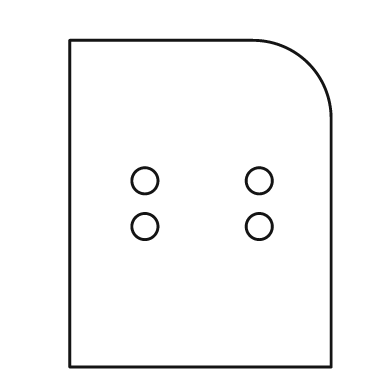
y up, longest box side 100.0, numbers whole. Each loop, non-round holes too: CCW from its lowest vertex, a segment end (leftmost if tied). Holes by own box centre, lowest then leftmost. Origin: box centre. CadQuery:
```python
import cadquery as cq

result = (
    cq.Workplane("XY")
    .moveTo(-40.0, -50.0)
    .lineTo(40.0, -50.0)
    .lineTo(40.0, 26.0)
    .threePointArc((33.0, 43.0), (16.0, 50.0))
    .lineTo(-40.0, 50.0)
    .close()
    .moveTo(-17.0, -7.0)
    .circle(4.0)
    .moveTo(18.0, -7.0)
    .circle(4.0)
    .moveTo(-17.0, 7.0)
    .circle(4.0)
    .moveTo(18.0, 7.0)
    .circle(4.0)
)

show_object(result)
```